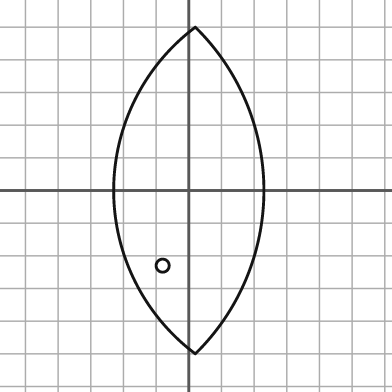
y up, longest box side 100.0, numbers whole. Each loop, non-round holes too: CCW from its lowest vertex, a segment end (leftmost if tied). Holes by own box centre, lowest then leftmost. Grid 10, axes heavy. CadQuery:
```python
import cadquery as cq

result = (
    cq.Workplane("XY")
    .moveTo(2.0, -50.0)
    .threePointArc((23.0, 0.0), (2.0, 50.0))
    .threePointArc((-23.0, 0.0), (2.0, -50.0))
    .close()
    .moveTo(-8.0, -23.0)
    .circle(2.0)
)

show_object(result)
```